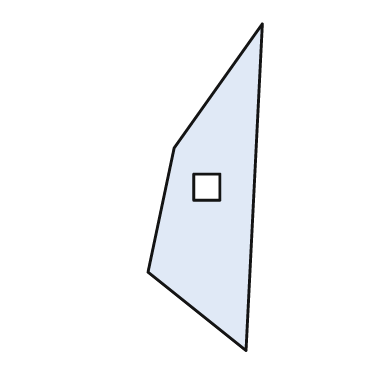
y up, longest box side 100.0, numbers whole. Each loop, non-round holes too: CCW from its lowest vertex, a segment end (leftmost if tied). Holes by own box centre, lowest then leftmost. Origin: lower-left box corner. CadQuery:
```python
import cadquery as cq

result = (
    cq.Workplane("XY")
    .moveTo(30.0, 0.0)
    .lineTo(35.0, 100.0)
    .lineTo(8.0, 62.0)
    .lineTo(0.0, 24.0)
    .close()
    .moveTo(14.0, 46.0)
    .lineTo(22.0, 46.0)
    .lineTo(22.0, 54.0)
    .lineTo(14.0, 54.0)
    .close()
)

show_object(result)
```